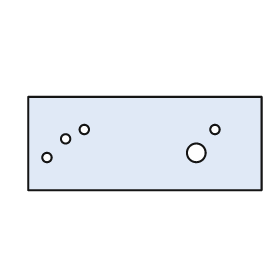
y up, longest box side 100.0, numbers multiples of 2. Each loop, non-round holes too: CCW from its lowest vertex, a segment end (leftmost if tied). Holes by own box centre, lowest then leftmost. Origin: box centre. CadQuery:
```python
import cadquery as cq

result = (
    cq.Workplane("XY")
    .moveTo(-50.0, -20.0)
    .lineTo(50.0, -20.0)
    .lineTo(50.0, 20.0)
    .lineTo(-50.0, 20.0)
    .close()
    .moveTo(-42.0, -6.0)
    .circle(2.0)
    .moveTo(22.0, -4.0)
    .circle(4.0)
    .moveTo(-34.0, 2.0)
    .circle(2.0)
    .moveTo(-26.0, 6.0)
    .circle(2.0)
    .moveTo(30.0, 6.0)
    .circle(2.0)
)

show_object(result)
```